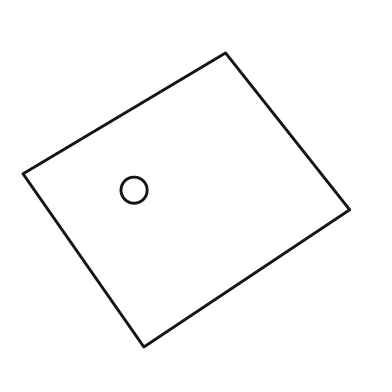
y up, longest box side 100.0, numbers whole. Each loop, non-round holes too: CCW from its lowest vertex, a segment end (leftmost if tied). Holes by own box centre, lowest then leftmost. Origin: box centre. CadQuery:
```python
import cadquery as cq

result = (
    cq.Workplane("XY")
    .moveTo(-13.0, -45.0)
    .lineTo(50.0, -3.0)
    .lineTo(12.0, 45.0)
    .lineTo(-50.0, 8.0)
    .close()
    .moveTo(-16.0, 3.0)
    .circle(4.0)
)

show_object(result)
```